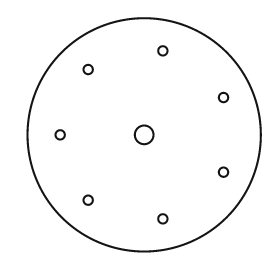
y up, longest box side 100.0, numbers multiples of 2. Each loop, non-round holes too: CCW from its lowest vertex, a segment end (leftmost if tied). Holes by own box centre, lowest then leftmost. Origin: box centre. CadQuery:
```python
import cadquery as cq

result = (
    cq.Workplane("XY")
    .moveTo(0.0, 0.0)
    .circle(50.0)
    .moveTo(8.0, -36.0)
    .circle(2.0)
    .moveTo(-24.0, -28.0)
    .circle(2.0)
    .moveTo(34.0, -16.0)
    .circle(2.0)
    .moveTo(-36.0, 0.0)
    .circle(2.0)
    .moveTo(0.0, 0.0)
    .circle(4.0)
    .moveTo(34.0, 16.0)
    .circle(2.0)
    .moveTo(-24.0, 28.0)
    .circle(2.0)
    .moveTo(8.0, 36.0)
    .circle(2.0)
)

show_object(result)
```